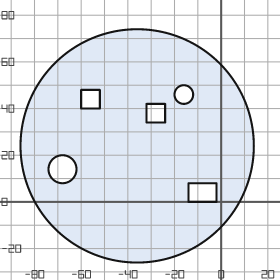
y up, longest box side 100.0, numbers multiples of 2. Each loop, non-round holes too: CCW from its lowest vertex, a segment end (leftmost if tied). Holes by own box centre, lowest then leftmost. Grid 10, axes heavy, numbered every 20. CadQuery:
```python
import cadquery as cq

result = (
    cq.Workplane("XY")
    .moveTo(-36.0, 24.0)
    .circle(50.0)
    .moveTo(-14.0, 0.0)
    .lineTo(-2.0, 0.0)
    .lineTo(-2.0, 8.0)
    .lineTo(-14.0, 8.0)
    .close()
    .moveTo(-68.0, 14.0)
    .circle(6.0)
    .moveTo(-32.0, 34.0)
    .lineTo(-24.0, 34.0)
    .lineTo(-24.0, 42.0)
    .lineTo(-32.0, 42.0)
    .close()
    .moveTo(-60.0, 40.0)
    .lineTo(-52.0, 40.0)
    .lineTo(-52.0, 48.0)
    .lineTo(-60.0, 48.0)
    .close()
    .moveTo(-16.0, 46.0)
    .circle(4.0)
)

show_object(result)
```